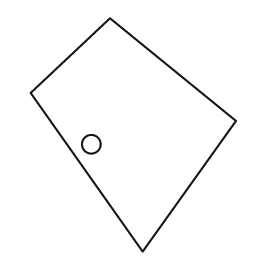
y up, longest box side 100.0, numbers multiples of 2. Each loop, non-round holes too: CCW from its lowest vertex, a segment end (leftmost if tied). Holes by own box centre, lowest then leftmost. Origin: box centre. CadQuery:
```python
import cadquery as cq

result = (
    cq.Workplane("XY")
    .moveTo(4.0, -50.0)
    .lineTo(44.0, 6.0)
    .lineTo(-10.0, 50.0)
    .lineTo(-44.0, 18.0)
    .close()
    .moveTo(-18.0, -4.0)
    .circle(4.0)
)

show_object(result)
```